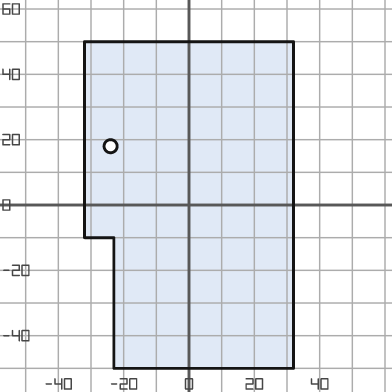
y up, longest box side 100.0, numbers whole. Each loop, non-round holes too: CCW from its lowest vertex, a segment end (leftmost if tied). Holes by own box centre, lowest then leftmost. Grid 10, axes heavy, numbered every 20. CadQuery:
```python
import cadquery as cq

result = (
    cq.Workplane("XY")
    .moveTo(-23.0, -50.0)
    .lineTo(32.0, -50.0)
    .lineTo(32.0, 50.0)
    .lineTo(-32.0, 50.0)
    .lineTo(-32.0, -10.0)
    .lineTo(-23.0, -10.0)
    .close()
    .moveTo(-24.0, 18.0)
    .circle(2.0)
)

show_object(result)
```